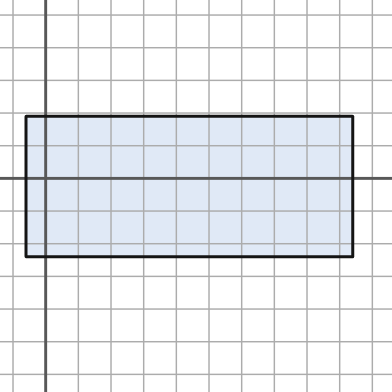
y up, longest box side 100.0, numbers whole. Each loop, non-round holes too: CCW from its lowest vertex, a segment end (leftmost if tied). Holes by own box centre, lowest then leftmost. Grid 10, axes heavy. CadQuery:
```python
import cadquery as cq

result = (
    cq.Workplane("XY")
    .moveTo(-6.0, -24.0)
    .lineTo(94.0, -24.0)
    .lineTo(94.0, 19.0)
    .lineTo(-6.0, 19.0)
    .close()
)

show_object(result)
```